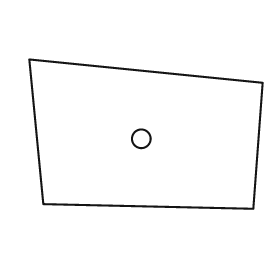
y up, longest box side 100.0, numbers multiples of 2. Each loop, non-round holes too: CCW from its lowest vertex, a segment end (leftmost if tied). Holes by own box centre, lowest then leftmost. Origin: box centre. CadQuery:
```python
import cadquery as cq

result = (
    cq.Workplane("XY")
    .moveTo(46.0, -32.0)
    .lineTo(50.0, 22.0)
    .lineTo(-50.0, 32.0)
    .lineTo(-44.0, -30.0)
    .close()
    .moveTo(-2.0, -2.0)
    .circle(4.0)
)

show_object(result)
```